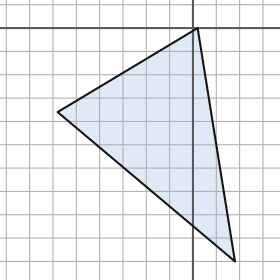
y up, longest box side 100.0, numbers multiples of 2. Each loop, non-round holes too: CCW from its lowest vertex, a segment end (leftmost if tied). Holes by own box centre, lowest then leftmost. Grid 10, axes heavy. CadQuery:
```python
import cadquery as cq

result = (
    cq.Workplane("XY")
    .moveTo(18.0, -100.0)
    .lineTo(2.0, 0.0)
    .lineTo(-58.0, -36.0)
    .close()
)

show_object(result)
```